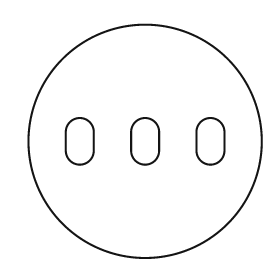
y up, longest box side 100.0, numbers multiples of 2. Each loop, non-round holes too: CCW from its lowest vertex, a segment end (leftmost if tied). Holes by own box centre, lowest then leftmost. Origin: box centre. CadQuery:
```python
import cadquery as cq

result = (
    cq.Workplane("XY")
    .moveTo(0.0, 0.0)
    .circle(50.0)
    .moveTo(-34.0, -4.0)
    .threePointArc((-28.0, -10.0), (-22.0, -4.0))
    .lineTo(-22.0, 4.0)
    .threePointArc((-28.0, 10.0), (-34.0, 4.0))
    .close()
    .moveTo(-6.0, -4.0)
    .threePointArc((0.0, -10.0), (6.0, -4.0))
    .lineTo(6.0, 4.0)
    .threePointArc((0.0, 10.0), (-6.0, 4.0))
    .close()
    .moveTo(22.0, -4.0)
    .threePointArc((28.0, -10.0), (34.0, -4.0))
    .lineTo(34.0, 4.0)
    .threePointArc((28.0, 10.0), (22.0, 4.0))
    .close()
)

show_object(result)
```